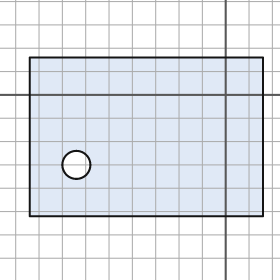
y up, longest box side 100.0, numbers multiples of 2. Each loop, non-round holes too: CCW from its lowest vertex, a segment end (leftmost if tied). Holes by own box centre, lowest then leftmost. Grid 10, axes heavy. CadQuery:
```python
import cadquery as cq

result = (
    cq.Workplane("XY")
    .moveTo(-84.0, -52.0)
    .lineTo(16.0, -52.0)
    .lineTo(16.0, 16.0)
    .lineTo(-84.0, 16.0)
    .close()
    .moveTo(-64.0, -30.0)
    .circle(6.0)
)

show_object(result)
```